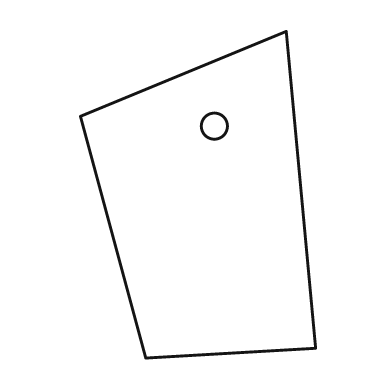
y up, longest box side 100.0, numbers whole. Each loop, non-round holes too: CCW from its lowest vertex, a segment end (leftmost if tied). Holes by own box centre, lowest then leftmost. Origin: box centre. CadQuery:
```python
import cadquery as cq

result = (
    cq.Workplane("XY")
    .moveTo(-16.0, -50.0)
    .lineTo(36.0, -47.0)
    .lineTo(27.0, 50.0)
    .lineTo(-36.0, 24.0)
    .close()
    .moveTo(5.0, 21.0)
    .circle(4.0)
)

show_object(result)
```